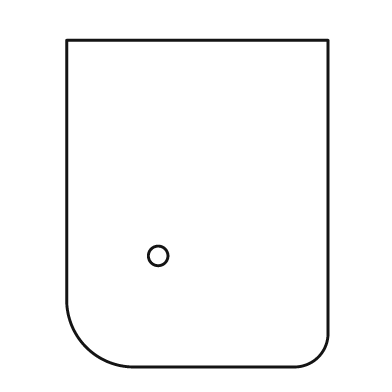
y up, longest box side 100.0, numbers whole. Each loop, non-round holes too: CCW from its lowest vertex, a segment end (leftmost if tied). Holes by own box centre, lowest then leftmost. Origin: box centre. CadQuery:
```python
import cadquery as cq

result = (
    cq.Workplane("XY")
    .moveTo(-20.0, -50.0)
    .lineTo(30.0, -50.0)
    .threePointArc((37.0, -47.0), (40.0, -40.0))
    .lineTo(40.0, 50.0)
    .lineTo(-40.0, 50.0)
    .lineTo(-40.0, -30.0)
    .threePointArc((-34.0, -44.0), (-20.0, -50.0))
    .close()
    .moveTo(-12.0, -16.0)
    .circle(3.0)
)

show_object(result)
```